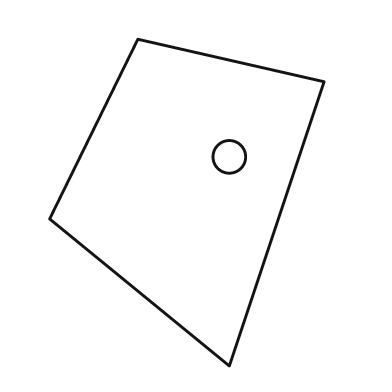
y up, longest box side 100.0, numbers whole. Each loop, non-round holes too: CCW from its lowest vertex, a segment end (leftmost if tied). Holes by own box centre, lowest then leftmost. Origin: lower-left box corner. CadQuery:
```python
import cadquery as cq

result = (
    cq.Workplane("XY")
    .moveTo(55.0, 0.0)
    .lineTo(84.0, 87.0)
    .lineTo(27.0, 100.0)
    .lineTo(0.0, 45.0)
    .close()
    .moveTo(55.0, 64.0)
    .circle(5.0)
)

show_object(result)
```